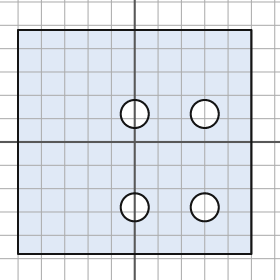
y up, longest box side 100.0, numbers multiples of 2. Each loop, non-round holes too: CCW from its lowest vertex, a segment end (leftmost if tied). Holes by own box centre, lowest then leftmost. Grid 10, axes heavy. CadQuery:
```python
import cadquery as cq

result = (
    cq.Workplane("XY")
    .moveTo(-50.0, -48.0)
    .lineTo(50.0, -48.0)
    .lineTo(50.0, 48.0)
    .lineTo(-50.0, 48.0)
    .close()
    .moveTo(0.0, -28.0)
    .circle(6.0)
    .moveTo(30.0, -28.0)
    .circle(6.0)
    .moveTo(0.0, 12.0)
    .circle(6.0)
    .moveTo(30.0, 12.0)
    .circle(6.0)
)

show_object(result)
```